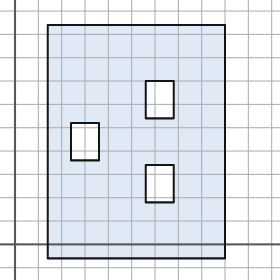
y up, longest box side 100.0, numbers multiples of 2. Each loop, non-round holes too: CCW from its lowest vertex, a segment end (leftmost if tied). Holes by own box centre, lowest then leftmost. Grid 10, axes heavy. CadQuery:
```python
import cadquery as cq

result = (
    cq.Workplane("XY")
    .moveTo(14.0, -6.0)
    .lineTo(90.0, -6.0)
    .lineTo(90.0, 94.0)
    .lineTo(14.0, 94.0)
    .close()
    .moveTo(56.0, 18.0)
    .lineTo(68.0, 18.0)
    .lineTo(68.0, 34.0)
    .lineTo(56.0, 34.0)
    .close()
    .moveTo(24.0, 36.0)
    .lineTo(36.0, 36.0)
    .lineTo(36.0, 52.0)
    .lineTo(24.0, 52.0)
    .close()
    .moveTo(56.0, 54.0)
    .lineTo(68.0, 54.0)
    .lineTo(68.0, 70.0)
    .lineTo(56.0, 70.0)
    .close()
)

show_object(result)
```